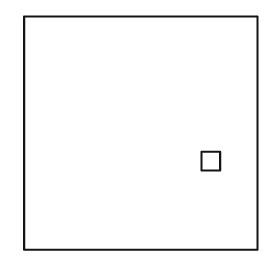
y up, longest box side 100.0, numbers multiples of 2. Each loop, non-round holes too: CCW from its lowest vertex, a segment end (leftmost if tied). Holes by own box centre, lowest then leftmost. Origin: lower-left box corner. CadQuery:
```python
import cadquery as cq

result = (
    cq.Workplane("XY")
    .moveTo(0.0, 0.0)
    .lineTo(100.0, 0.0)
    .lineTo(100.0, 100.0)
    .lineTo(0.0, 100.0)
    .close()
    .moveTo(76.0, 34.0)
    .lineTo(84.0, 34.0)
    .lineTo(84.0, 42.0)
    .lineTo(76.0, 42.0)
    .close()
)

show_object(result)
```